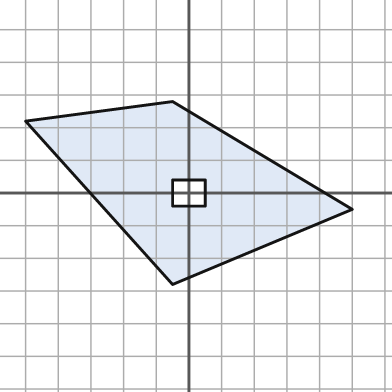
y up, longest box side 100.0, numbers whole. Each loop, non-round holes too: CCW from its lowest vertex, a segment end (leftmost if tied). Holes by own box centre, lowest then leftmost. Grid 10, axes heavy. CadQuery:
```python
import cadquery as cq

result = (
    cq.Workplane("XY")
    .moveTo(-5.0, -28.0)
    .lineTo(50.0, -5.0)
    .lineTo(-5.0, 28.0)
    .lineTo(-50.0, 22.0)
    .close()
    .moveTo(-5.0, -4.0)
    .lineTo(5.0, -4.0)
    .lineTo(5.0, 4.0)
    .lineTo(-5.0, 4.0)
    .close()
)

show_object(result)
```